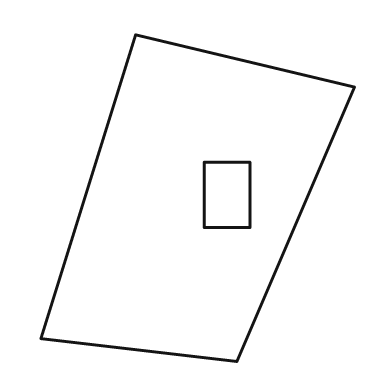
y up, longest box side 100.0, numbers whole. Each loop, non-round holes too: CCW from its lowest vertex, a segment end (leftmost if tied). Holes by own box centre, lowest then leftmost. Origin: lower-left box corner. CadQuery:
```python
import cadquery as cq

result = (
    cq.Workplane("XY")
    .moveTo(60.0, 0.0)
    .lineTo(96.0, 84.0)
    .lineTo(29.0, 100.0)
    .lineTo(0.0, 7.0)
    .close()
    .moveTo(50.0, 41.0)
    .lineTo(64.0, 41.0)
    .lineTo(64.0, 61.0)
    .lineTo(50.0, 61.0)
    .close()
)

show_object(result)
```